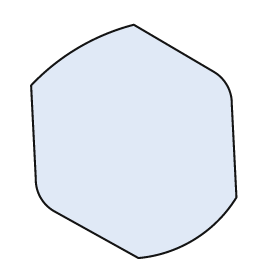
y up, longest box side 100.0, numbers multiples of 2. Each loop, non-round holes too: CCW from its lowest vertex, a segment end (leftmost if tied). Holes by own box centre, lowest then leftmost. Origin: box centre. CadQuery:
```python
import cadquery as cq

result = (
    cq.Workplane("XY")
    .moveTo(2.0, -50.0)
    .threePointArc((26.0, -42.0), (44.0, -24.0))
    .lineTo(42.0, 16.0)
    .threePointArc((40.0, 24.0), (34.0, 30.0))
    .lineTo(0.0, 50.0)
    .threePointArc((-24.0, 40.0), (-44.0, 24.0))
    .lineTo(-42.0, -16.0)
    .threePointArc((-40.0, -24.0), (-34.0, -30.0))
    .close()
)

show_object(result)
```